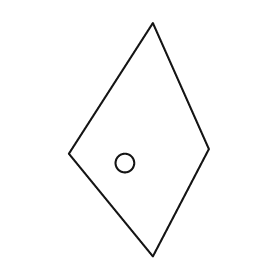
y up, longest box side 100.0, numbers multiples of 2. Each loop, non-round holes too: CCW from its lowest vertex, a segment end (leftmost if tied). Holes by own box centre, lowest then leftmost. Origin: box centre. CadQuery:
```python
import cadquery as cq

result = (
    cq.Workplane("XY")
    .moveTo(6.0, -50.0)
    .lineTo(30.0, -4.0)
    .lineTo(6.0, 50.0)
    .lineTo(-30.0, -6.0)
    .close()
    .moveTo(-6.0, -10.0)
    .circle(4.0)
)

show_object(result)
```